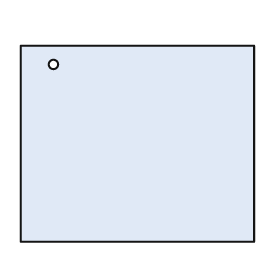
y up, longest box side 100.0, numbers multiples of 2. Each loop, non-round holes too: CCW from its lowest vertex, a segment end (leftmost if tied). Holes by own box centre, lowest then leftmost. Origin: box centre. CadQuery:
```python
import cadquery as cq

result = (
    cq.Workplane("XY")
    .moveTo(-50.0, -42.0)
    .lineTo(50.0, -42.0)
    .lineTo(50.0, 42.0)
    .lineTo(-50.0, 42.0)
    .close()
    .moveTo(-36.0, 34.0)
    .circle(2.0)
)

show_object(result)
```